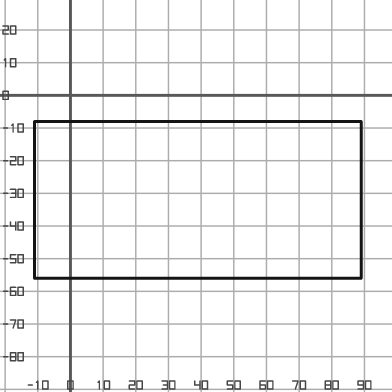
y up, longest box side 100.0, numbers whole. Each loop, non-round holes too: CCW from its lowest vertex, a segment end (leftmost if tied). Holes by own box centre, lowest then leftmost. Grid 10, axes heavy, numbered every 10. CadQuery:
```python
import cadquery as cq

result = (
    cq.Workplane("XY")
    .moveTo(-11.0, -56.0)
    .lineTo(89.0, -56.0)
    .lineTo(89.0, -8.0)
    .lineTo(-11.0, -8.0)
    .close()
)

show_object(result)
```